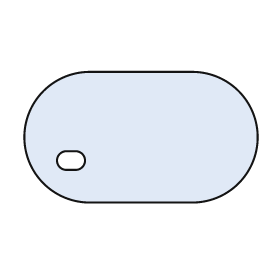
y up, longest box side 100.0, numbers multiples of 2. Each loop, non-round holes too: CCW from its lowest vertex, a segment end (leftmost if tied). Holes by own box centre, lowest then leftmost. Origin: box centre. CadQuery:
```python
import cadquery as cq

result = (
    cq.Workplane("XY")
    .moveTo(-22.0, -28.0)
    .lineTo(22.0, -28.0)
    .threePointArc((50.0, 0.0), (22.0, 28.0))
    .lineTo(-22.0, 28.0)
    .threePointArc((-50.0, 0.0), (-22.0, -28.0))
    .close()
    .moveTo(-32.0, -14.0)
    .lineTo(-28.0, -14.0)
    .threePointArc((-24.0, -10.0), (-28.0, -6.0))
    .lineTo(-32.0, -6.0)
    .threePointArc((-36.0, -10.0), (-32.0, -14.0))
    .close()
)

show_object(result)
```